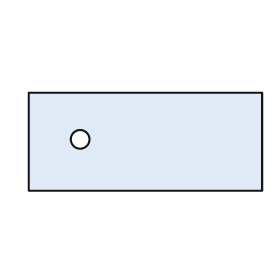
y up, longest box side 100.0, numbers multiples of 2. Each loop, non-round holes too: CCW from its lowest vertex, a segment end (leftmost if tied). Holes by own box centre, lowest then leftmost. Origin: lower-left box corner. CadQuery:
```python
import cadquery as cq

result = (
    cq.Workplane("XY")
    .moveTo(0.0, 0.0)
    .lineTo(100.0, 0.0)
    .lineTo(100.0, 42.0)
    .lineTo(0.0, 42.0)
    .close()
    .moveTo(22.0, 22.0)
    .circle(4.0)
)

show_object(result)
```